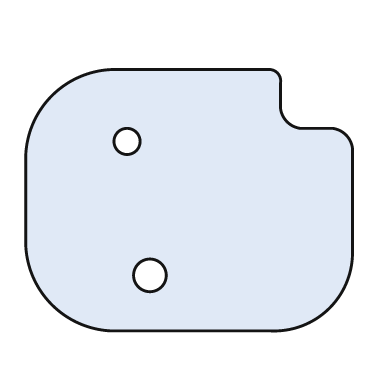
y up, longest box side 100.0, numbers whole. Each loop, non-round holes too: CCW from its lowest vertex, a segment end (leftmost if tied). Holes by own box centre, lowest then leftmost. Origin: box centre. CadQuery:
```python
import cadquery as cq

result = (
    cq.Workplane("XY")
    .moveTo(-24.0, -40.0)
    .lineTo(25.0, -40.0)
    .threePointArc((43.0, -33.0), (50.0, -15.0))
    .lineTo(50.0, 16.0)
    .threePointArc((48.0, 20.0), (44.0, 22.0))
    .lineTo(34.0, 22.0)
    .threePointArc((30.0, 24.0), (28.0, 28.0))
    .lineTo(28.0, 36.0)
    .threePointArc((27.0, 39.0), (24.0, 40.0))
    .lineTo(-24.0, 40.0)
    .threePointArc((-42.0, 32.0), (-50.0, 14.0))
    .lineTo(-50.0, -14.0)
    .threePointArc((-42.0, -32.0), (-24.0, -40.0))
    .close()
    .moveTo(-12.0, -23.0)
    .circle(5.0)
    .moveTo(-19.0, 18.0)
    .circle(4.0)
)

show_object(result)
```